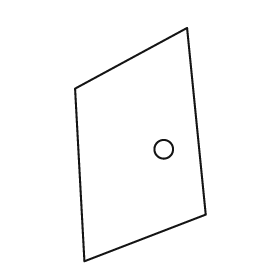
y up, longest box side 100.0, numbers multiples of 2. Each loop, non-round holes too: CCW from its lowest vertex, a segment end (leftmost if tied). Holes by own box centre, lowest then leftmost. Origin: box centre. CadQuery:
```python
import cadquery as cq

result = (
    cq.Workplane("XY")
    .moveTo(-24.0, -50.0)
    .lineTo(28.0, -30.0)
    .lineTo(20.0, 50.0)
    .lineTo(-28.0, 24.0)
    .close()
    .moveTo(10.0, -2.0)
    .circle(4.0)
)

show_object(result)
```